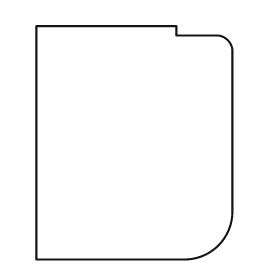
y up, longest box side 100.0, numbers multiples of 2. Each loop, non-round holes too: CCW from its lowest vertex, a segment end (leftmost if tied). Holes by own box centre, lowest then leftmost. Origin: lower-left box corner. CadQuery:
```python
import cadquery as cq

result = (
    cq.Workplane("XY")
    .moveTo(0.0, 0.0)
    .lineTo(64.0, 0.0)
    .threePointArc((78.0, 6.0), (84.0, 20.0))
    .lineTo(84.0, 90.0)
    .threePointArc((82.0, 94.0), (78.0, 96.0))
    .lineTo(60.0, 96.0)
    .lineTo(60.0, 100.0)
    .lineTo(0.0, 100.0)
    .close()
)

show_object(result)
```